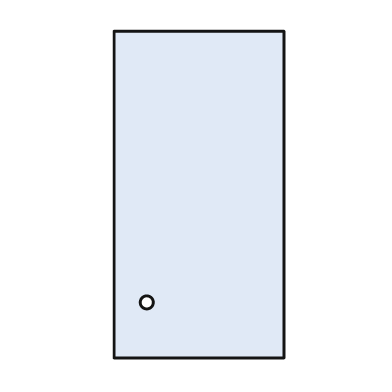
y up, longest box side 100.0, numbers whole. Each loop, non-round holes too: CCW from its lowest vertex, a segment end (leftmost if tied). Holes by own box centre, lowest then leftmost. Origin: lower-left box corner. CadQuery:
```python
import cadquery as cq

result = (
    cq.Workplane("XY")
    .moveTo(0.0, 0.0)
    .lineTo(52.0, 0.0)
    .lineTo(52.0, 100.0)
    .lineTo(0.0, 100.0)
    .close()
    .moveTo(10.0, 17.0)
    .circle(2.0)
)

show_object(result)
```